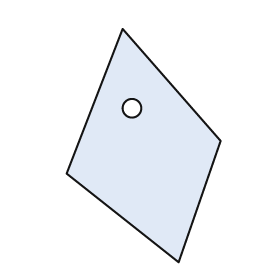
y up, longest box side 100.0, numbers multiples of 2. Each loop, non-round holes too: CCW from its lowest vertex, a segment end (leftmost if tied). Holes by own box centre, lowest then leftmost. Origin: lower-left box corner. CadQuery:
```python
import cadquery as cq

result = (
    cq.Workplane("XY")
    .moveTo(48.0, 0.0)
    .lineTo(66.0, 52.0)
    .lineTo(24.0, 100.0)
    .lineTo(0.0, 38.0)
    .close()
    .moveTo(28.0, 66.0)
    .circle(4.0)
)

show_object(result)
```